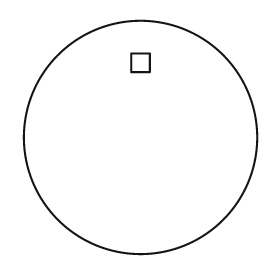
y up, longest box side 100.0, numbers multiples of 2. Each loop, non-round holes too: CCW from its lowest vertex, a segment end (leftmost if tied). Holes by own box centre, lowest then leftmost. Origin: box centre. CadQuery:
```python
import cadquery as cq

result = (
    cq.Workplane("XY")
    .moveTo(0.0, 0.0)
    .circle(50.0)
    .moveTo(-4.0, 28.0)
    .lineTo(4.0, 28.0)
    .lineTo(4.0, 36.0)
    .lineTo(-4.0, 36.0)
    .close()
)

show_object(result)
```